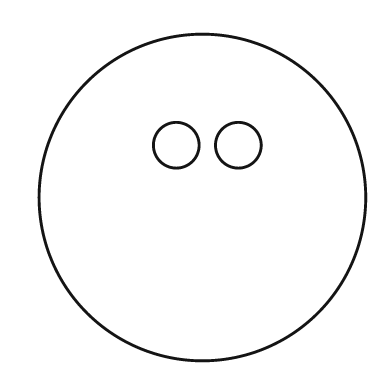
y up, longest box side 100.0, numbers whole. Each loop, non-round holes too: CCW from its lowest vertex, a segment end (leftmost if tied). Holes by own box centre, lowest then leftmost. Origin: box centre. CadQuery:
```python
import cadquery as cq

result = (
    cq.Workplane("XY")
    .moveTo(0.0, 0.0)
    .circle(50.0)
    .moveTo(-8.0, 16.0)
    .circle(7.0)
    .moveTo(11.0, 16.0)
    .circle(7.0)
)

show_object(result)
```